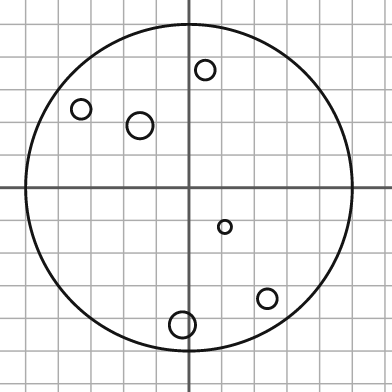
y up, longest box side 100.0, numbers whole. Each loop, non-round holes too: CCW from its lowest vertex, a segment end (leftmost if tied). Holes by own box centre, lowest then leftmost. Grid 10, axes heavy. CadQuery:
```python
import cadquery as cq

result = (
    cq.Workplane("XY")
    .moveTo(0.0, 0.0)
    .circle(50.0)
    .moveTo(-2.0, -42.0)
    .circle(4.0)
    .moveTo(24.0, -34.0)
    .circle(3.0)
    .moveTo(11.0, -12.0)
    .circle(2.0)
    .moveTo(-15.0, 19.0)
    .circle(4.0)
    .moveTo(-33.0, 24.0)
    .circle(3.0)
    .moveTo(5.0, 36.0)
    .circle(3.0)
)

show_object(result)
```